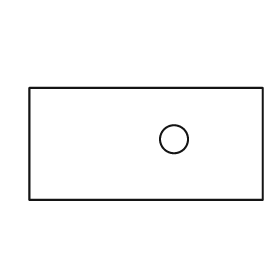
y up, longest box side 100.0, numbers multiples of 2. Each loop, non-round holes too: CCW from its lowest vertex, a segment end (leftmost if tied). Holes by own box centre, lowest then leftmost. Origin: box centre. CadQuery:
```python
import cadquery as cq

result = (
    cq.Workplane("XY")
    .moveTo(-50.0, -24.0)
    .lineTo(50.0, -24.0)
    .lineTo(50.0, 24.0)
    .lineTo(-50.0, 24.0)
    .close()
    .moveTo(12.0, 2.0)
    .circle(6.0)
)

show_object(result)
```